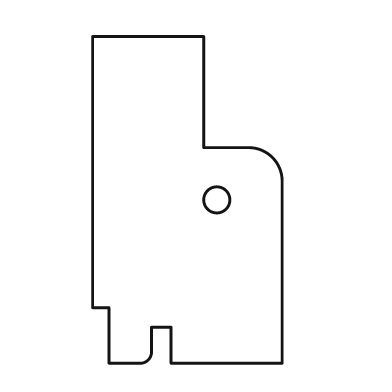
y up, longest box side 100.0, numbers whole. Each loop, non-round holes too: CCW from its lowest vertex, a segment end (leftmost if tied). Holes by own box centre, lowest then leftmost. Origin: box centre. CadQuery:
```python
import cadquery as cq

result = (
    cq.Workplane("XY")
    .moveTo(-24.0, -50.0)
    .lineTo(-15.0, -50.0)
    .threePointArc((-12.0, -49.0), (-11.0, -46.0))
    .lineTo(-11.0, -39.0)
    .lineTo(-5.0, -39.0)
    .lineTo(-5.0, -50.0)
    .lineTo(29.0, -50.0)
    .lineTo(29.0, 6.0)
    .threePointArc((26.0, 13.0), (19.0, 16.0))
    .lineTo(5.0, 16.0)
    .lineTo(5.0, 50.0)
    .lineTo(-29.0, 50.0)
    .lineTo(-29.0, -33.0)
    .lineTo(-24.0, -33.0)
    .close()
    .moveTo(9.0, 0.0)
    .circle(4.0)
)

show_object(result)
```